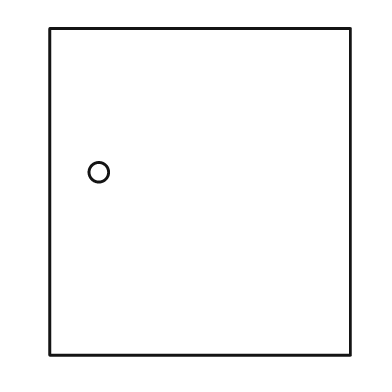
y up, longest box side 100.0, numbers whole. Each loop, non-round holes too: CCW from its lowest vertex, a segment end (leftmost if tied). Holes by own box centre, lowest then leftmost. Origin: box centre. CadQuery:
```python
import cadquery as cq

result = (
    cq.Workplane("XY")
    .moveTo(-46.0, -50.0)
    .lineTo(46.0, -50.0)
    .lineTo(46.0, 50.0)
    .lineTo(-46.0, 50.0)
    .close()
    .moveTo(-31.0, 6.0)
    .circle(3.0)
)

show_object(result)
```